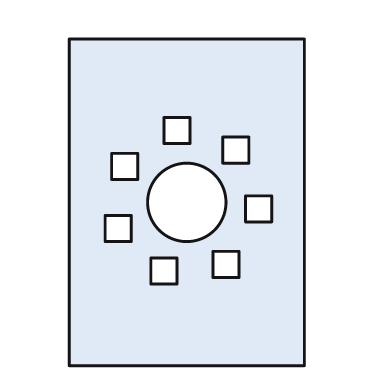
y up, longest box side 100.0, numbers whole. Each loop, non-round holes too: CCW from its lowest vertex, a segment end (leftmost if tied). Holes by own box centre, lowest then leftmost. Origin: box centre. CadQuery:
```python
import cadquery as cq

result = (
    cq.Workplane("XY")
    .moveTo(-36.0, -50.0)
    .lineTo(36.0, -50.0)
    .lineTo(36.0, 50.0)
    .lineTo(-36.0, 50.0)
    .close()
    .moveTo(-11.0, -25.0)
    .lineTo(-3.0, -25.0)
    .lineTo(-3.0, -17.0)
    .lineTo(-11.0, -17.0)
    .close()
    .moveTo(8.0, -23.0)
    .lineTo(16.0, -23.0)
    .lineTo(16.0, -15.0)
    .lineTo(8.0, -15.0)
    .close()
    .moveTo(-25.0, -12.0)
    .lineTo(-17.0, -12.0)
    .lineTo(-17.0, -4.0)
    .lineTo(-25.0, -4.0)
    .close()
    .moveTo(18.0, -6.0)
    .lineTo(26.0, -6.0)
    .lineTo(26.0, 2.0)
    .lineTo(18.0, 2.0)
    .close()
    .moveTo(0.0, 0.0)
    .circle(12.0)
    .moveTo(-23.0, 7.0)
    .lineTo(-15.0, 7.0)
    .lineTo(-15.0, 15.0)
    .lineTo(-23.0, 15.0)
    .close()
    .moveTo(11.0, 12.0)
    .lineTo(19.0, 12.0)
    .lineTo(19.0, 20.0)
    .lineTo(11.0, 20.0)
    .close()
    .moveTo(-7.0, 18.0)
    .lineTo(1.0, 18.0)
    .lineTo(1.0, 26.0)
    .lineTo(-7.0, 26.0)
    .close()
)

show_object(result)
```